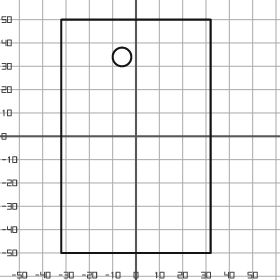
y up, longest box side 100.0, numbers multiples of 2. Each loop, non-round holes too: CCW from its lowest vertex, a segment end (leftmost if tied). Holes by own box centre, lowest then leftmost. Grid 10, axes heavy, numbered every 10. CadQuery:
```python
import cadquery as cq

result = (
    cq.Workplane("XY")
    .moveTo(-32.0, -50.0)
    .lineTo(32.0, -50.0)
    .lineTo(32.0, 50.0)
    .lineTo(-32.0, 50.0)
    .close()
    .moveTo(-6.0, 34.0)
    .circle(4.0)
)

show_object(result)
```